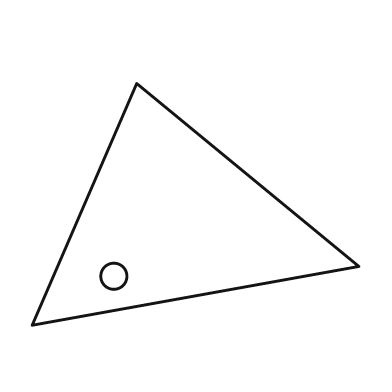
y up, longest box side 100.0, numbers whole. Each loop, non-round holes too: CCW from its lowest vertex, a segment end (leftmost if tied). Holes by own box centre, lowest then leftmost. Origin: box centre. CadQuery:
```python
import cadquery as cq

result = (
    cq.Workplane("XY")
    .moveTo(-50.0, -37.0)
    .lineTo(50.0, -19.0)
    .lineTo(-18.0, 37.0)
    .close()
    .moveTo(-25.0, -22.0)
    .circle(4.0)
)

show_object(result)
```